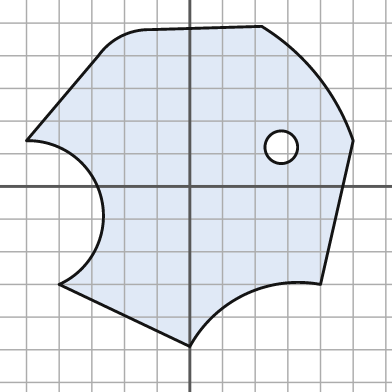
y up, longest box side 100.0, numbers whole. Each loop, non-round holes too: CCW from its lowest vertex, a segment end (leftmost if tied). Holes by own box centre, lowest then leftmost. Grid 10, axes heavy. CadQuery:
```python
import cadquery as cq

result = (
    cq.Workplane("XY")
    .moveTo(0.0, -49.0)
    .threePointArc((17.0, -33.0), (40.0, -30.0))
    .lineTo(50.0, 14.0)
    .threePointArc((39.0, 34.0), (22.0, 49.0))
    .lineTo(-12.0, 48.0)
    .threePointArc((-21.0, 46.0), (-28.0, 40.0))
    .lineTo(-50.0, 14.0)
    .threePointArc((-27.0, -4.0), (-40.0, -30.0))
    .close()
    .moveTo(28.0, 12.0)
    .circle(5.0)
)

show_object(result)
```